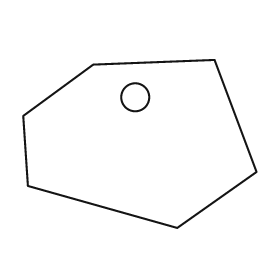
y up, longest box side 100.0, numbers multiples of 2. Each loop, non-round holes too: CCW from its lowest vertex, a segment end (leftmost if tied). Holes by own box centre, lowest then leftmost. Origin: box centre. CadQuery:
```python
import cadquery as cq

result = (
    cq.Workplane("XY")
    .moveTo(16.0, -36.0)
    .lineTo(50.0, -12.0)
    .lineTo(32.0, 36.0)
    .lineTo(-20.0, 34.0)
    .lineTo(-50.0, 12.0)
    .lineTo(-48.0, -18.0)
    .close()
    .moveTo(-2.0, 20.0)
    .circle(6.0)
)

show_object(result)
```